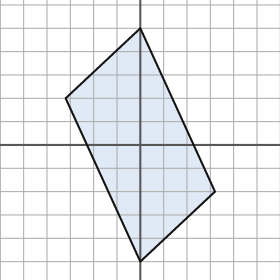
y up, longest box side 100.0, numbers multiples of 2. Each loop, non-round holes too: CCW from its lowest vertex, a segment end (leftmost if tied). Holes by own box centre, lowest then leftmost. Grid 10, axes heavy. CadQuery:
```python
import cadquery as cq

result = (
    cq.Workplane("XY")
    .moveTo(0.0, -50.0)
    .lineTo(32.0, -20.0)
    .lineTo(0.0, 50.0)
    .lineTo(-32.0, 20.0)
    .close()
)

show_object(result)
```